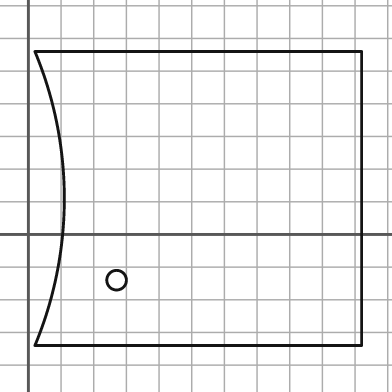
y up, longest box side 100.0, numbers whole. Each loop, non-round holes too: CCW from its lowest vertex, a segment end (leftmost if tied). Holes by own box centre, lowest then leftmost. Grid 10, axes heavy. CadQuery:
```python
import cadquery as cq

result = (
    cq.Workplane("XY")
    .moveTo(2.0, -34.0)
    .lineTo(102.0, -34.0)
    .lineTo(102.0, 56.0)
    .lineTo(2.0, 56.0)
    .threePointArc((11.0, 11.0), (2.0, -34.0))
    .close()
    .moveTo(27.0, -14.0)
    .circle(3.0)
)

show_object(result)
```